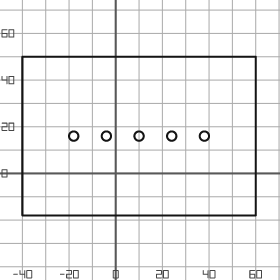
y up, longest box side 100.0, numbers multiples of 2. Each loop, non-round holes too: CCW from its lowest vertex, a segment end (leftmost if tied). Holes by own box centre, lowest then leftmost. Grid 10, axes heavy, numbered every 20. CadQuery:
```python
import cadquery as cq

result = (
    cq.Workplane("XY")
    .moveTo(-40.0, -18.0)
    .lineTo(60.0, -18.0)
    .lineTo(60.0, 50.0)
    .lineTo(-40.0, 50.0)
    .close()
    .moveTo(-18.0, 16.0)
    .circle(2.0)
    .moveTo(-4.0, 16.0)
    .circle(2.0)
    .moveTo(10.0, 16.0)
    .circle(2.0)
    .moveTo(24.0, 16.0)
    .circle(2.0)
    .moveTo(38.0, 16.0)
    .circle(2.0)
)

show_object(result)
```